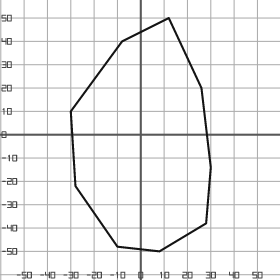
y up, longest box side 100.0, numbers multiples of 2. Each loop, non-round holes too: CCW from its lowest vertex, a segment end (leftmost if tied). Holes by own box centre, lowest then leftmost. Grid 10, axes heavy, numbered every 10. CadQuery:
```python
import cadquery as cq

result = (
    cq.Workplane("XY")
    .moveTo(8.0, -50.0)
    .lineTo(28.0, -38.0)
    .lineTo(30.0, -14.0)
    .lineTo(26.0, 20.0)
    .lineTo(12.0, 50.0)
    .lineTo(-8.0, 40.0)
    .lineTo(-30.0, 10.0)
    .lineTo(-28.0, -22.0)
    .lineTo(-10.0, -48.0)
    .close()
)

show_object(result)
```